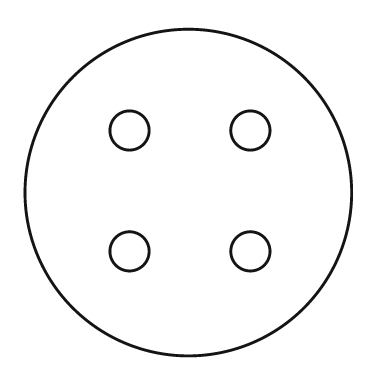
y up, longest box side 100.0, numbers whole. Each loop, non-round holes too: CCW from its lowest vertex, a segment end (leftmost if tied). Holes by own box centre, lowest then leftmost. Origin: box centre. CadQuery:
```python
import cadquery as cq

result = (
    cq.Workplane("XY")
    .moveTo(0.0, 0.0)
    .circle(50.0)
    .moveTo(-18.0, -18.0)
    .circle(6.0)
    .moveTo(19.0, -18.0)
    .circle(6.0)
    .moveTo(-18.0, 19.0)
    .circle(6.0)
    .moveTo(19.0, 19.0)
    .circle(6.0)
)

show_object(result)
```